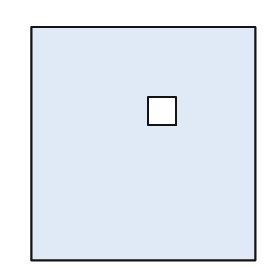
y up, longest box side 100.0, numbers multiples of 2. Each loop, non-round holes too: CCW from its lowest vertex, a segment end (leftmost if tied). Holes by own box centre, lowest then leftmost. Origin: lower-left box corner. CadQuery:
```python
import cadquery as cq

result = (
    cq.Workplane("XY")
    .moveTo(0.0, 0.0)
    .lineTo(96.0, 0.0)
    .lineTo(96.0, 100.0)
    .lineTo(0.0, 100.0)
    .close()
    .moveTo(50.0, 58.0)
    .lineTo(62.0, 58.0)
    .lineTo(62.0, 70.0)
    .lineTo(50.0, 70.0)
    .close()
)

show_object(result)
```